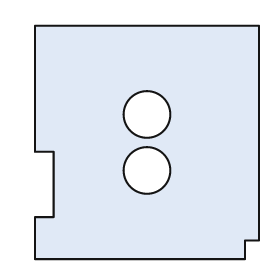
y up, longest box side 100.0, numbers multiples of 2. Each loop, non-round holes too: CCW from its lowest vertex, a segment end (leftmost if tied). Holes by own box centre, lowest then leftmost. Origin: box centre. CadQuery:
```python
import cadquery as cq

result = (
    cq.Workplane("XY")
    .moveTo(-48.0, -50.0)
    .lineTo(42.0, -50.0)
    .lineTo(42.0, -42.0)
    .lineTo(48.0, -42.0)
    .lineTo(48.0, 50.0)
    .lineTo(-48.0, 50.0)
    .lineTo(-48.0, -4.0)
    .lineTo(-40.0, -4.0)
    .lineTo(-40.0, -32.0)
    .lineTo(-48.0, -32.0)
    .close()
    .moveTo(0.0, -12.0)
    .circle(10.0)
    .moveTo(0.0, 12.0)
    .circle(10.0)
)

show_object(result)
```